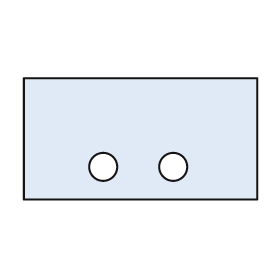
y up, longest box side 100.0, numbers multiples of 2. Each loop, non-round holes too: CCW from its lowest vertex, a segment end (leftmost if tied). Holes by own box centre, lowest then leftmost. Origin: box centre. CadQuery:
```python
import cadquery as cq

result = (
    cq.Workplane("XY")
    .moveTo(-50.0, -26.0)
    .lineTo(50.0, -26.0)
    .lineTo(50.0, 26.0)
    .lineTo(-50.0, 26.0)
    .close()
    .moveTo(-16.0, -12.0)
    .circle(6.0)
    .moveTo(14.0, -12.0)
    .circle(6.0)
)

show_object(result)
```